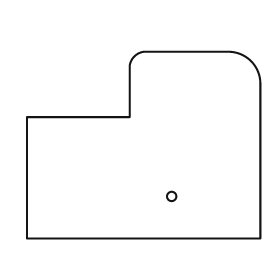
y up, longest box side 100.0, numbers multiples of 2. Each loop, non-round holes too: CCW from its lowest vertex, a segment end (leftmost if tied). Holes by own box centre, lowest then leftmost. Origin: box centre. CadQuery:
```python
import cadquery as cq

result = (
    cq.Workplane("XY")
    .moveTo(-50.0, -40.0)
    .lineTo(50.0, -40.0)
    .lineTo(50.0, 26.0)
    .threePointArc((46.0, 36.0), (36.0, 40.0))
    .lineTo(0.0, 40.0)
    .threePointArc((-4.0, 38.0), (-6.0, 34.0))
    .lineTo(-6.0, 12.0)
    .lineTo(-50.0, 12.0)
    .close()
    .moveTo(12.0, -22.0)
    .circle(2.0)
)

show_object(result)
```